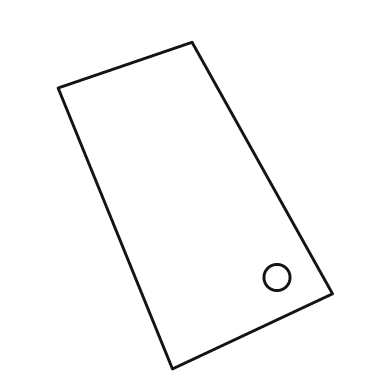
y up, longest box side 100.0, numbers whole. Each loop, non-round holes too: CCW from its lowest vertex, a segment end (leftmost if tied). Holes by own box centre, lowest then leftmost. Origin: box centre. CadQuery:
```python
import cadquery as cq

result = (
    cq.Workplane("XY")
    .moveTo(-7.0, -50.0)
    .lineTo(42.0, -27.0)
    .lineTo(-1.0, 50.0)
    .lineTo(-42.0, 36.0)
    .close()
    .moveTo(25.0, -22.0)
    .circle(4.0)
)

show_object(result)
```